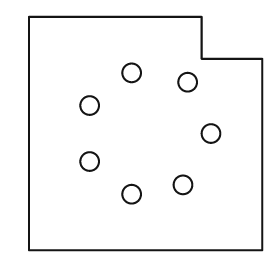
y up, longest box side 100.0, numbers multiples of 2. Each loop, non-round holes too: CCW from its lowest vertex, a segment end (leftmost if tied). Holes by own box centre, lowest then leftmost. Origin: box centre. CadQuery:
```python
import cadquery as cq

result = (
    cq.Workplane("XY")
    .moveTo(-50.0, -50.0)
    .lineTo(50.0, -50.0)
    .lineTo(50.0, 32.0)
    .lineTo(24.0, 32.0)
    .lineTo(24.0, 50.0)
    .lineTo(-50.0, 50.0)
    .close()
    .moveTo(-6.0, -26.0)
    .circle(4.0)
    .moveTo(16.0, -22.0)
    .circle(4.0)
    .moveTo(-24.0, -12.0)
    .circle(4.0)
    .moveTo(28.0, 0.0)
    .circle(4.0)
    .moveTo(-24.0, 12.0)
    .circle(4.0)
    .moveTo(18.0, 22.0)
    .circle(4.0)
    .moveTo(-6.0, 26.0)
    .circle(4.0)
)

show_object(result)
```